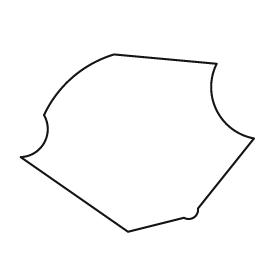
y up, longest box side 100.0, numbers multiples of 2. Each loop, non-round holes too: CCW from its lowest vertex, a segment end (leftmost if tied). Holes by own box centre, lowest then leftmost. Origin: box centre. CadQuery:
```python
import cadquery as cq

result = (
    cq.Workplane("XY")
    .moveTo(-4.0, -38.0)
    .lineTo(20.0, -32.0)
    .threePointArc((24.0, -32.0), (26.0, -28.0))
    .lineTo(50.0, 2.0)
    .threePointArc((34.0, 14.0), (34.0, 34.0))
    .lineTo(-10.0, 38.0)
    .threePointArc((-28.0, 28.0), (-40.0, 12.0))
    .threePointArc((-40.0, 0.0), (-50.0, -6.0))
    .close()
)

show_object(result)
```